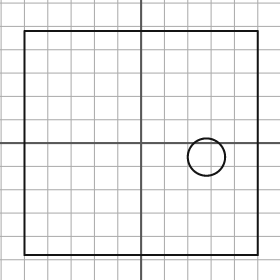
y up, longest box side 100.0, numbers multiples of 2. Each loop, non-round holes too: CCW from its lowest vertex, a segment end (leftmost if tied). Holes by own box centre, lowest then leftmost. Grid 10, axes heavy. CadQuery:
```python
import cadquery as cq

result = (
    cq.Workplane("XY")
    .moveTo(-50.0, -48.0)
    .lineTo(50.0, -48.0)
    .lineTo(50.0, 48.0)
    .lineTo(-50.0, 48.0)
    .close()
    .moveTo(28.0, -6.0)
    .circle(8.0)
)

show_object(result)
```